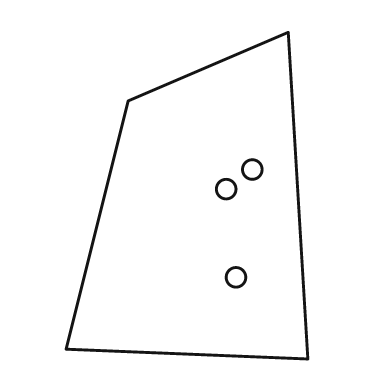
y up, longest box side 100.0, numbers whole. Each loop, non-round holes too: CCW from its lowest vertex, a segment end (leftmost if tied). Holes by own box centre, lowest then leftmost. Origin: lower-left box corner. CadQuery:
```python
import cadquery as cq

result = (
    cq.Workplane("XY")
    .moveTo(74.0, 0.0)
    .lineTo(68.0, 100.0)
    .lineTo(19.0, 79.0)
    .lineTo(0.0, 3.0)
    .close()
    .moveTo(52.0, 25.0)
    .circle(3.0)
    .moveTo(49.0, 52.0)
    .circle(3.0)
    .moveTo(57.0, 58.0)
    .circle(3.0)
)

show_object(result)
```